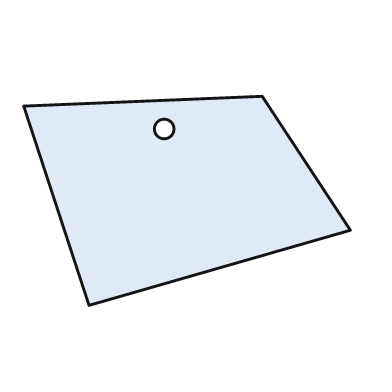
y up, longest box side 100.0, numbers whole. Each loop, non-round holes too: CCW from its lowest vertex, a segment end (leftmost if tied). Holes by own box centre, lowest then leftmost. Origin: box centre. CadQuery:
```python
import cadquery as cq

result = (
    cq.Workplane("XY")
    .moveTo(-30.0, -32.0)
    .lineTo(50.0, -9.0)
    .lineTo(23.0, 32.0)
    .lineTo(-50.0, 29.0)
    .close()
    .moveTo(-7.0, 22.0)
    .circle(3.0)
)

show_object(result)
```